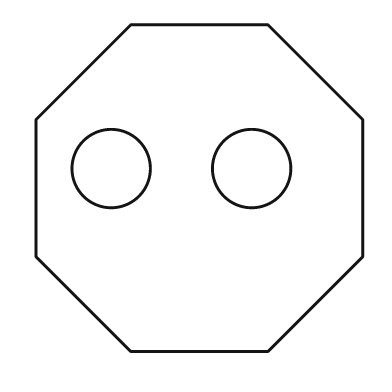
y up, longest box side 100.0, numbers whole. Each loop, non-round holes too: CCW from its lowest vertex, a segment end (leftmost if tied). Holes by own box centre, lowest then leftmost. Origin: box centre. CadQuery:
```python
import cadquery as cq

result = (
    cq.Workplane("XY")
    .moveTo(-21.0, -50.0)
    .lineTo(21.0, -50.0)
    .lineTo(50.0, -21.0)
    .lineTo(50.0, 21.0)
    .lineTo(21.0, 50.0)
    .lineTo(-21.0, 50.0)
    .lineTo(-50.0, 21.0)
    .lineTo(-50.0, -21.0)
    .close()
    .moveTo(-27.0, 6.0)
    .circle(12.0)
    .moveTo(16.0, 6.0)
    .circle(12.0)
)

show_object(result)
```